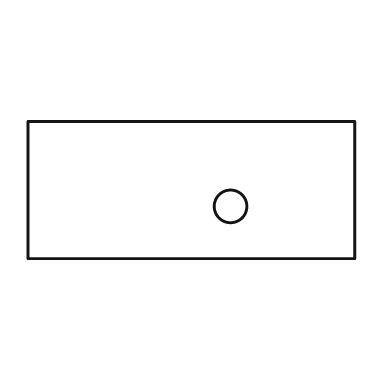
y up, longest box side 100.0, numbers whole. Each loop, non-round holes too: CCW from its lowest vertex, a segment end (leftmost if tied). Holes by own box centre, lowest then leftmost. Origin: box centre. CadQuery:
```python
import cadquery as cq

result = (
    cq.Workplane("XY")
    .moveTo(-50.0, -21.0)
    .lineTo(50.0, -21.0)
    .lineTo(50.0, 21.0)
    .lineTo(-50.0, 21.0)
    .close()
    .moveTo(12.0, -5.0)
    .circle(5.0)
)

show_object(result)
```